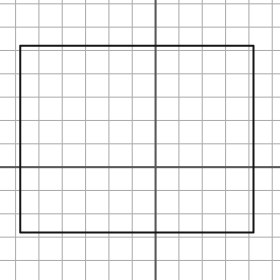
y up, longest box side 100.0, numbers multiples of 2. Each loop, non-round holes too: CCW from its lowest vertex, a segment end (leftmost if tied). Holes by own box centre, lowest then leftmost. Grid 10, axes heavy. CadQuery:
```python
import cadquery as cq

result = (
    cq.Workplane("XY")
    .moveTo(-58.0, -28.0)
    .lineTo(42.0, -28.0)
    .lineTo(42.0, 52.0)
    .lineTo(-58.0, 52.0)
    .close()
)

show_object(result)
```